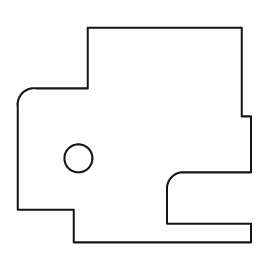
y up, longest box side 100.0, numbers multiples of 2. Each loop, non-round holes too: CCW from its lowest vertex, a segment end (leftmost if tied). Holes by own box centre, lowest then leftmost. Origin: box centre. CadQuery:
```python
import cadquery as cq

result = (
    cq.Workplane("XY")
    .moveTo(-26.0, -46.0)
    .lineTo(50.0, -46.0)
    .lineTo(50.0, -38.0)
    .lineTo(14.0, -38.0)
    .lineTo(14.0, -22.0)
    .threePointArc((16.0, -18.0), (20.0, -16.0))
    .lineTo(50.0, -16.0)
    .lineTo(50.0, 8.0)
    .lineTo(46.0, 8.0)
    .lineTo(46.0, 46.0)
    .lineTo(-20.0, 46.0)
    .lineTo(-20.0, 20.0)
    .lineTo(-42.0, 20.0)
    .threePointArc((-48.0, 18.0), (-50.0, 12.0))
    .lineTo(-50.0, -32.0)
    .lineTo(-26.0, -32.0)
    .close()
    .moveTo(-24.0, -10.0)
    .circle(6.0)
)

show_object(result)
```